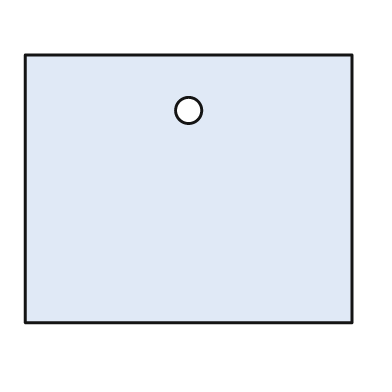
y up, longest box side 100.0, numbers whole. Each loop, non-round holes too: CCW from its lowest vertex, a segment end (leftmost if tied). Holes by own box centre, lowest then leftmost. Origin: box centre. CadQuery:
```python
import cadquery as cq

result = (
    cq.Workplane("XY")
    .moveTo(-50.0, -41.0)
    .lineTo(50.0, -41.0)
    .lineTo(50.0, 41.0)
    .lineTo(-50.0, 41.0)
    .close()
    .moveTo(0.0, 24.0)
    .circle(4.0)
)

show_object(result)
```